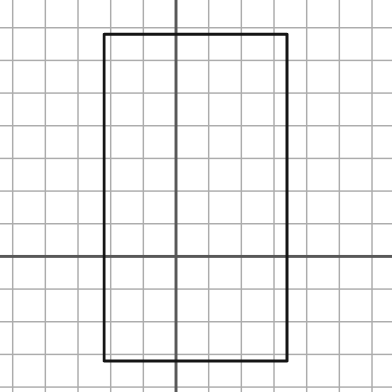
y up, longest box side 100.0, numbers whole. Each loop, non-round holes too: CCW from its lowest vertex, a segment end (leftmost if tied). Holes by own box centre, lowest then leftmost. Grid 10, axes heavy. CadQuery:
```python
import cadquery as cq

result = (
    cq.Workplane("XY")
    .moveTo(-22.0, -32.0)
    .lineTo(34.0, -32.0)
    .lineTo(34.0, 68.0)
    .lineTo(-22.0, 68.0)
    .close()
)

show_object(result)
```